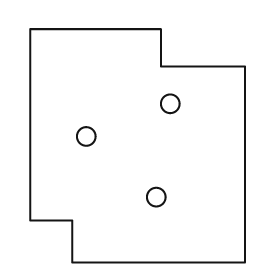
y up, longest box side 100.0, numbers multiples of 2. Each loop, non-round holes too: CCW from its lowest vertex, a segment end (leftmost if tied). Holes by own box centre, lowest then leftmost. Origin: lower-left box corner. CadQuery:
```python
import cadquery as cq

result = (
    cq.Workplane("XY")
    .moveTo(18.0, 0.0)
    .lineTo(92.0, 0.0)
    .lineTo(92.0, 84.0)
    .lineTo(56.0, 84.0)
    .lineTo(56.0, 100.0)
    .lineTo(0.0, 100.0)
    .lineTo(0.0, 18.0)
    .lineTo(18.0, 18.0)
    .close()
    .moveTo(54.0, 28.0)
    .circle(4.0)
    .moveTo(24.0, 54.0)
    .circle(4.0)
    .moveTo(60.0, 68.0)
    .circle(4.0)
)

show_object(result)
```